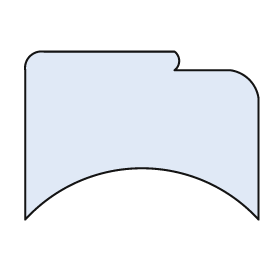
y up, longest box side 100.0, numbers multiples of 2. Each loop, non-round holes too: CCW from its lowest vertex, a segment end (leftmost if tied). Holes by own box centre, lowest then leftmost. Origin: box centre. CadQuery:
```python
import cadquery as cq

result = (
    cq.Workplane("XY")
    .moveTo(-50.0, -36.0)
    .threePointArc((0.0, -14.0), (50.0, -36.0))
    .lineTo(50.0, 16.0)
    .threePointArc((46.0, 24.0), (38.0, 28.0))
    .lineTo(14.0, 28.0)
    .threePointArc((16.0, 32.0), (14.0, 36.0))
    .lineTo(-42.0, 36.0)
    .threePointArc((-48.0, 34.0), (-50.0, 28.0))
    .close()
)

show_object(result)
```